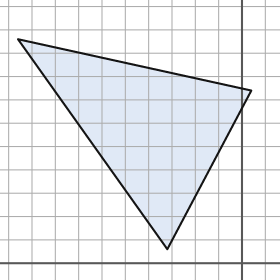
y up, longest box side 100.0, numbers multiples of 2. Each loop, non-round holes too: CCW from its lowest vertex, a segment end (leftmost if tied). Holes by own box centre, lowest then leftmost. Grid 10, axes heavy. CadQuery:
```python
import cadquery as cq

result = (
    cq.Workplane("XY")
    .moveTo(-32.0, 6.0)
    .lineTo(4.0, 74.0)
    .lineTo(-96.0, 96.0)
    .close()
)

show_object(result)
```